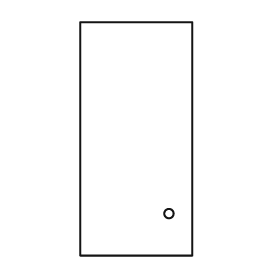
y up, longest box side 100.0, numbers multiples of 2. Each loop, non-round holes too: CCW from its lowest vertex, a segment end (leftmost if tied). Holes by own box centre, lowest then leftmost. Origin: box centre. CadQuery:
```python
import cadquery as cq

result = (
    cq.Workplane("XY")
    .moveTo(-24.0, -50.0)
    .lineTo(24.0, -50.0)
    .lineTo(24.0, 50.0)
    .lineTo(-24.0, 50.0)
    .close()
    .moveTo(14.0, -32.0)
    .circle(2.0)
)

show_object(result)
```